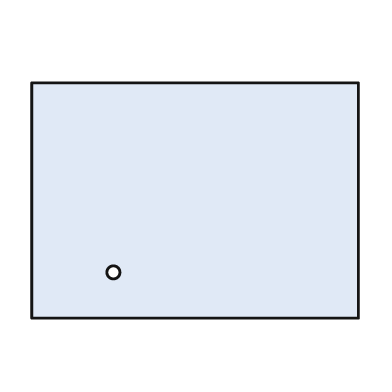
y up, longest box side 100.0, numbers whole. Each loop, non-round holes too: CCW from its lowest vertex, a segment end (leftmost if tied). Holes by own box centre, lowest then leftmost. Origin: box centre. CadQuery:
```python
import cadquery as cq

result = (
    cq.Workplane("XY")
    .moveTo(-50.0, -36.0)
    .lineTo(50.0, -36.0)
    .lineTo(50.0, 36.0)
    .lineTo(-50.0, 36.0)
    .close()
    .moveTo(-25.0, -22.0)
    .circle(2.0)
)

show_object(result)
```